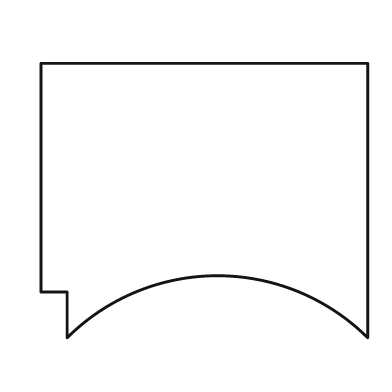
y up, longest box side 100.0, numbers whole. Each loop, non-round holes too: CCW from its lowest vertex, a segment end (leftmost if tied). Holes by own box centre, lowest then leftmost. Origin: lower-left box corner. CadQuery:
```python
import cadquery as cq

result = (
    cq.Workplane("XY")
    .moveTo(8.0, 0.0)
    .threePointArc((54.0, 19.0), (100.0, 0.0))
    .lineTo(100.0, 84.0)
    .lineTo(0.0, 84.0)
    .lineTo(0.0, 14.0)
    .lineTo(8.0, 14.0)
    .close()
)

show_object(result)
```